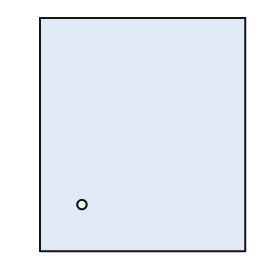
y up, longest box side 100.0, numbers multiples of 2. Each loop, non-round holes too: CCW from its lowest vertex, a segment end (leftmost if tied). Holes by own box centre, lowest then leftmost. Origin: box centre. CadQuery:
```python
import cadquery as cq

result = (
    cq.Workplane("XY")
    .moveTo(-44.0, -50.0)
    .lineTo(44.0, -50.0)
    .lineTo(44.0, 50.0)
    .lineTo(-44.0, 50.0)
    .close()
    .moveTo(-26.0, -30.0)
    .circle(2.0)
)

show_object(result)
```